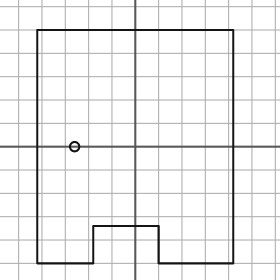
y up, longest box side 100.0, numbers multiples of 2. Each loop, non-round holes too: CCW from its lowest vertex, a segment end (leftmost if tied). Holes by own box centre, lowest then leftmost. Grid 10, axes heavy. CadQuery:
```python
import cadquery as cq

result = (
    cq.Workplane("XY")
    .moveTo(-42.0, -50.0)
    .lineTo(-18.0, -50.0)
    .lineTo(-18.0, -34.0)
    .lineTo(10.0, -34.0)
    .lineTo(10.0, -50.0)
    .lineTo(42.0, -50.0)
    .lineTo(42.0, 50.0)
    .lineTo(-42.0, 50.0)
    .close()
    .moveTo(-26.0, 0.0)
    .circle(2.0)
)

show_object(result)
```